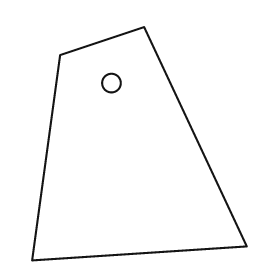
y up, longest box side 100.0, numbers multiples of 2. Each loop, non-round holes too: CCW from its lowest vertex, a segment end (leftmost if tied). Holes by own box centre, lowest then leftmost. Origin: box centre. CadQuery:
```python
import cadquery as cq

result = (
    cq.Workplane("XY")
    .moveTo(-46.0, -50.0)
    .lineTo(46.0, -44.0)
    .lineTo(2.0, 50.0)
    .lineTo(-34.0, 38.0)
    .close()
    .moveTo(-12.0, 26.0)
    .circle(4.0)
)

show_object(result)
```